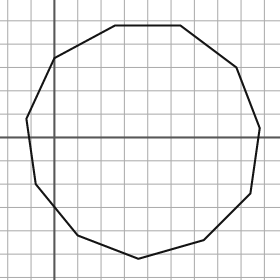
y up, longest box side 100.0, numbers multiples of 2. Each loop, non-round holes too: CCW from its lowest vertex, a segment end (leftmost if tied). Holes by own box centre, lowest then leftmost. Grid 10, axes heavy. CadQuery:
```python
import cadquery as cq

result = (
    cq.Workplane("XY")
    .moveTo(36.0, -52.0)
    .lineTo(64.0, -44.0)
    .lineTo(84.0, -24.0)
    .lineTo(88.0, 4.0)
    .lineTo(78.0, 30.0)
    .lineTo(54.0, 48.0)
    .lineTo(26.0, 48.0)
    .lineTo(0.0, 34.0)
    .lineTo(-12.0, 8.0)
    .lineTo(-8.0, -20.0)
    .lineTo(10.0, -42.0)
    .close()
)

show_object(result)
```